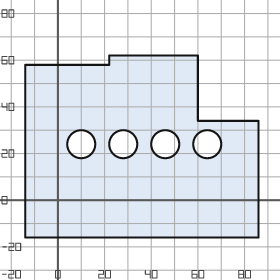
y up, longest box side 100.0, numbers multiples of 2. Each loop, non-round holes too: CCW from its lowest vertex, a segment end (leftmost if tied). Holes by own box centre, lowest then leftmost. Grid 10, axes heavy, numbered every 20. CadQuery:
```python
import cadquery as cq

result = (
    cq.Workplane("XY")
    .moveTo(-14.0, -16.0)
    .lineTo(86.0, -16.0)
    .lineTo(86.0, 34.0)
    .lineTo(60.0, 34.0)
    .lineTo(60.0, 62.0)
    .lineTo(22.0, 62.0)
    .lineTo(22.0, 58.0)
    .lineTo(-14.0, 58.0)
    .close()
    .moveTo(10.0, 24.0)
    .circle(6.0)
    .moveTo(28.0, 24.0)
    .circle(6.0)
    .moveTo(46.0, 24.0)
    .circle(6.0)
    .moveTo(64.0, 24.0)
    .circle(6.0)
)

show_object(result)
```